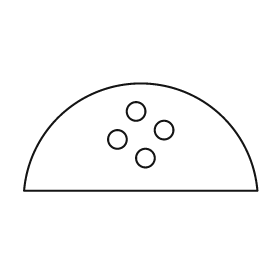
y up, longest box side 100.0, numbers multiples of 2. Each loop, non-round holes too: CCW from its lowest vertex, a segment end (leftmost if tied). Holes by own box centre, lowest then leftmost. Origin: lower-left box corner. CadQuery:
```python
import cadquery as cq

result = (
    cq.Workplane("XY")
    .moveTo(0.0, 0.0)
    .lineTo(100.0, 0.0)
    .threePointArc((50.0, 46.0), (0.0, 0.0))
    .close()
    .moveTo(52.0, 14.0)
    .circle(4.0)
    .moveTo(40.0, 22.0)
    .circle(4.0)
    .moveTo(60.0, 26.0)
    .circle(4.0)
    .moveTo(48.0, 34.0)
    .circle(4.0)
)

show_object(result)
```